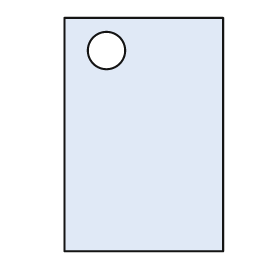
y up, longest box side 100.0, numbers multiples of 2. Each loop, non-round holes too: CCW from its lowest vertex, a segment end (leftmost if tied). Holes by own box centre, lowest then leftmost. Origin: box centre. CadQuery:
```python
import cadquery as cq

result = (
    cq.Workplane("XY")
    .moveTo(-34.0, -50.0)
    .lineTo(34.0, -50.0)
    .lineTo(34.0, 50.0)
    .lineTo(-34.0, 50.0)
    .close()
    .moveTo(-16.0, 36.0)
    .circle(8.0)
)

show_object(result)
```